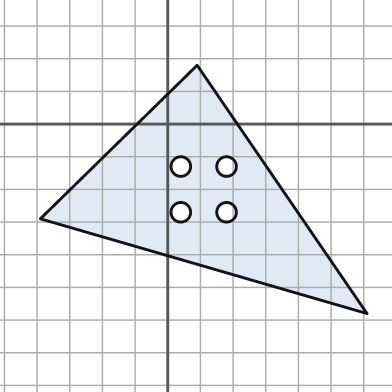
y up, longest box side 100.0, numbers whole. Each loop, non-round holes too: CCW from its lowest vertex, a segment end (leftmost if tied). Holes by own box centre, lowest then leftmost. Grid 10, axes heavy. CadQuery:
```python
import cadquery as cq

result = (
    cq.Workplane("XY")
    .moveTo(61.0, -58.0)
    .lineTo(9.0, 18.0)
    .lineTo(-39.0, -29.0)
    .close()
    .moveTo(4.0, -27.0)
    .circle(3.0)
    .moveTo(18.0, -27.0)
    .circle(3.0)
    .moveTo(4.0, -13.0)
    .circle(3.0)
    .moveTo(18.0, -13.0)
    .circle(3.0)
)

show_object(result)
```